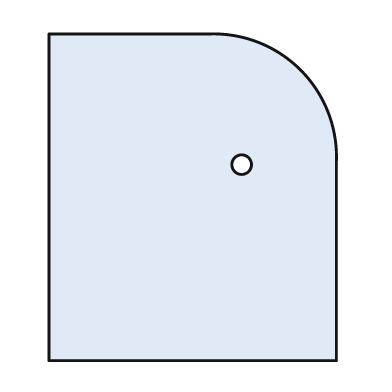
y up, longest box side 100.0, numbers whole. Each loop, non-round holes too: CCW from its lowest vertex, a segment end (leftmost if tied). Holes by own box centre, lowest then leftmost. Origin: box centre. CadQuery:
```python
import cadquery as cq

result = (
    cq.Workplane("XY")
    .moveTo(-44.0, -50.0)
    .lineTo(44.0, -50.0)
    .lineTo(44.0, 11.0)
    .threePointArc((33.0, 39.0), (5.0, 50.0))
    .lineTo(-44.0, 50.0)
    .close()
    .moveTo(15.0, 10.0)
    .circle(3.0)
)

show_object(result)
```